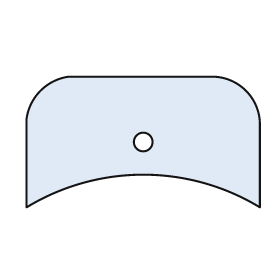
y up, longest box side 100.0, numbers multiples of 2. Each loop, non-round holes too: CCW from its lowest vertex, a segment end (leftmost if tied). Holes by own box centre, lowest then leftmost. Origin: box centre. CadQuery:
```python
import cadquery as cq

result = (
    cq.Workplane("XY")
    .moveTo(-50.0, -28.0)
    .threePointArc((0.0, -14.0), (50.0, -28.0))
    .lineTo(50.0, 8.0)
    .threePointArc((44.0, 22.0), (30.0, 28.0))
    .lineTo(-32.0, 28.0)
    .threePointArc((-44.0, 22.0), (-50.0, 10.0))
    .close()
    .moveTo(0.0, 0.0)
    .circle(4.0)
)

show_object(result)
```